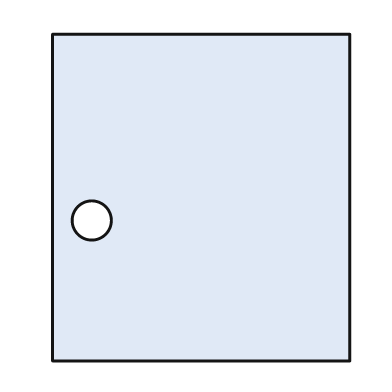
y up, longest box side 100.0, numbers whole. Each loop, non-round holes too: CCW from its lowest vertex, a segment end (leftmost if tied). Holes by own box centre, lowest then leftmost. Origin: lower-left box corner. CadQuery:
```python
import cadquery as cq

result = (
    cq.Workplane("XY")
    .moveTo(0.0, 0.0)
    .lineTo(91.0, 0.0)
    .lineTo(91.0, 100.0)
    .lineTo(0.0, 100.0)
    .close()
    .moveTo(12.0, 43.0)
    .circle(6.0)
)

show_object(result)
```